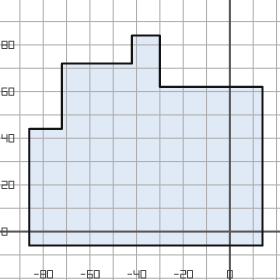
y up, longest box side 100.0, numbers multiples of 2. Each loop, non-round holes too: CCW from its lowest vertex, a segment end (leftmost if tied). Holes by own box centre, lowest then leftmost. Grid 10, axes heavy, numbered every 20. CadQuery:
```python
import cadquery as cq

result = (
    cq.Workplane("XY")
    .moveTo(-86.0, -6.0)
    .lineTo(14.0, -6.0)
    .lineTo(14.0, 62.0)
    .lineTo(-30.0, 62.0)
    .lineTo(-30.0, 84.0)
    .lineTo(-42.0, 84.0)
    .lineTo(-42.0, 72.0)
    .lineTo(-72.0, 72.0)
    .lineTo(-72.0, 44.0)
    .lineTo(-86.0, 44.0)
    .close()
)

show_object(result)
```